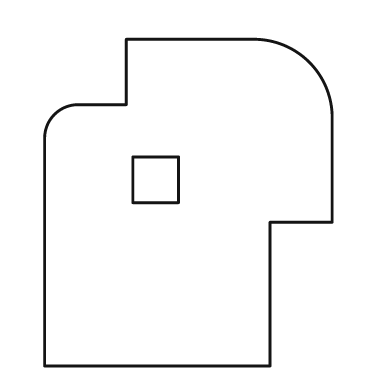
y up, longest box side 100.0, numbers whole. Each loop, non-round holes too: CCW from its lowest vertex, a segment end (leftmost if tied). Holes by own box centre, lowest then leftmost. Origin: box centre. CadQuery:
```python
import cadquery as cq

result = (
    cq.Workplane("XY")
    .moveTo(-44.0, -50.0)
    .lineTo(25.0, -50.0)
    .lineTo(25.0, -6.0)
    .lineTo(44.0, -6.0)
    .lineTo(44.0, 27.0)
    .threePointArc((37.0, 43.0), (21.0, 50.0))
    .lineTo(-19.0, 50.0)
    .lineTo(-19.0, 30.0)
    .lineTo(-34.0, 30.0)
    .threePointArc((-41.0, 27.0), (-44.0, 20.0))
    .close()
    .moveTo(-17.0, 0.0)
    .lineTo(-3.0, 0.0)
    .lineTo(-3.0, 14.0)
    .lineTo(-17.0, 14.0)
    .close()
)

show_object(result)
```